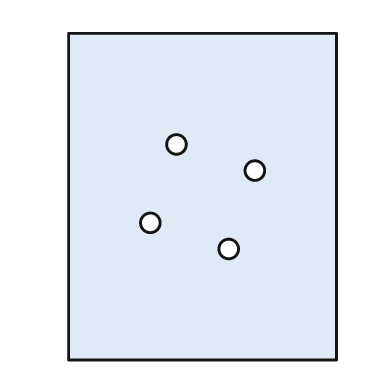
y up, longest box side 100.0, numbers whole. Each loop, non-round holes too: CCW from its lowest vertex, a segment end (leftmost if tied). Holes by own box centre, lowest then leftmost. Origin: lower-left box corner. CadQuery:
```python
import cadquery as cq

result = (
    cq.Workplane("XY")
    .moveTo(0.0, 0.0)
    .lineTo(82.0, 0.0)
    .lineTo(82.0, 100.0)
    .lineTo(0.0, 100.0)
    .close()
    .moveTo(49.0, 34.0)
    .circle(3.0)
    .moveTo(25.0, 42.0)
    .circle(3.0)
    .moveTo(57.0, 58.0)
    .circle(3.0)
    .moveTo(33.0, 66.0)
    .circle(3.0)
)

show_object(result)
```